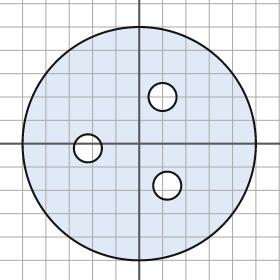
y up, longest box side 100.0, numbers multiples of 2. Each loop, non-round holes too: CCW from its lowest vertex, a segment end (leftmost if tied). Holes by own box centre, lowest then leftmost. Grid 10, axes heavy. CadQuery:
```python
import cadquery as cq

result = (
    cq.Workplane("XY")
    .moveTo(0.0, 0.0)
    .circle(50.0)
    .moveTo(12.0, -18.0)
    .circle(6.0)
    .moveTo(-22.0, -2.0)
    .circle(6.0)
    .moveTo(10.0, 20.0)
    .circle(6.0)
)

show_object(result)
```